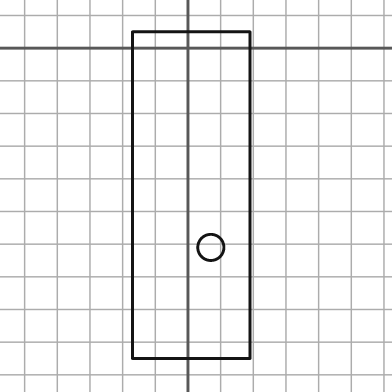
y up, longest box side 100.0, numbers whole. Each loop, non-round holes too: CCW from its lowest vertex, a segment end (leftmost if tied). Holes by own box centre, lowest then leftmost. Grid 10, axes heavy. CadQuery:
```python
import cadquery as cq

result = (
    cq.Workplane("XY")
    .moveTo(-17.0, -95.0)
    .lineTo(19.0, -95.0)
    .lineTo(19.0, 5.0)
    .lineTo(-17.0, 5.0)
    .close()
    .moveTo(7.0, -61.0)
    .circle(4.0)
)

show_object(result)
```